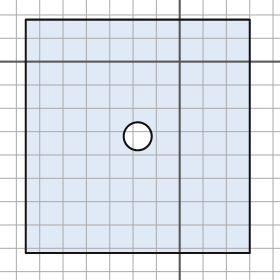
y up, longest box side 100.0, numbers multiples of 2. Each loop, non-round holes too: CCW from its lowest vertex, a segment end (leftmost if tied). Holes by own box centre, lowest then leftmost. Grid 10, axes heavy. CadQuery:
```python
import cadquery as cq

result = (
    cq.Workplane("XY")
    .moveTo(-66.0, -82.0)
    .lineTo(30.0, -82.0)
    .lineTo(30.0, 18.0)
    .lineTo(-66.0, 18.0)
    .close()
    .moveTo(-18.0, -32.0)
    .circle(6.0)
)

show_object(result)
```